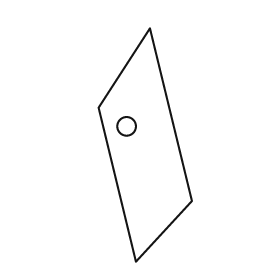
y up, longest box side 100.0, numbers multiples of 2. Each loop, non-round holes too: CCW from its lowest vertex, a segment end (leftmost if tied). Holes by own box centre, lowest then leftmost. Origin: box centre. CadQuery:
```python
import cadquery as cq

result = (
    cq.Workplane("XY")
    .moveTo(-4.0, -50.0)
    .lineTo(20.0, -24.0)
    .lineTo(2.0, 50.0)
    .lineTo(-20.0, 16.0)
    .close()
    .moveTo(-8.0, 8.0)
    .circle(4.0)
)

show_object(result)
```